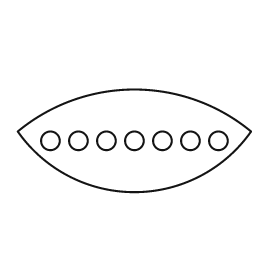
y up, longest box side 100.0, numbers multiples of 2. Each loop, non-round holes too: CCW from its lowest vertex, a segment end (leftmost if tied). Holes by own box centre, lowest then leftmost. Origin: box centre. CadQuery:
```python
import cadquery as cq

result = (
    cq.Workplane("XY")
    .moveTo(-50.0, 4.0)
    .threePointArc((0.0, -22.0), (50.0, 4.0))
    .threePointArc((0.0, 22.0), (-50.0, 4.0))
    .close()
    .moveTo(-36.0, 0.0)
    .circle(4.0)
    .moveTo(-24.0, 0.0)
    .circle(4.0)
    .moveTo(-12.0, 0.0)
    .circle(4.0)
    .moveTo(0.0, 0.0)
    .circle(4.0)
    .moveTo(12.0, 0.0)
    .circle(4.0)
    .moveTo(24.0, 0.0)
    .circle(4.0)
    .moveTo(36.0, 0.0)
    .circle(4.0)
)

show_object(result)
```